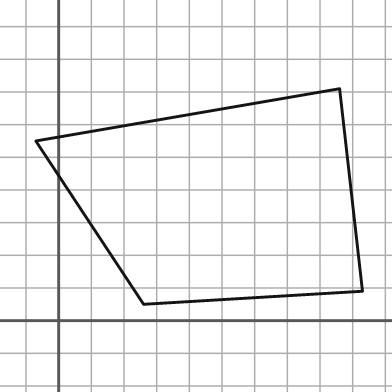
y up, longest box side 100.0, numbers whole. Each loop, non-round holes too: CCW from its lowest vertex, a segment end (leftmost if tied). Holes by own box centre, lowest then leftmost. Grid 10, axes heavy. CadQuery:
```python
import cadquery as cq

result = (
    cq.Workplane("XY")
    .moveTo(26.0, 5.0)
    .lineTo(93.0, 9.0)
    .lineTo(86.0, 71.0)
    .lineTo(-7.0, 55.0)
    .close()
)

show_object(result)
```